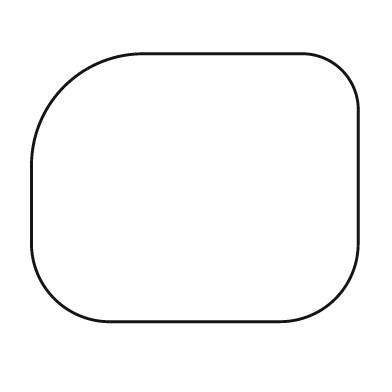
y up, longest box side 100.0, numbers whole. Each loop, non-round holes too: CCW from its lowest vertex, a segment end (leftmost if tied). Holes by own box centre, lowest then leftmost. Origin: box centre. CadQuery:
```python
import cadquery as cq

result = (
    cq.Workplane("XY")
    .moveTo(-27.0, -41.0)
    .lineTo(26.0, -41.0)
    .threePointArc((43.0, -34.0), (50.0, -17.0))
    .lineTo(50.0, 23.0)
    .threePointArc((45.0, 36.0), (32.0, 41.0))
    .lineTo(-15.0, 41.0)
    .threePointArc((-40.0, 31.0), (-50.0, 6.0))
    .lineTo(-50.0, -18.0)
    .threePointArc((-43.0, -34.0), (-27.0, -41.0))
    .close()
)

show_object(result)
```